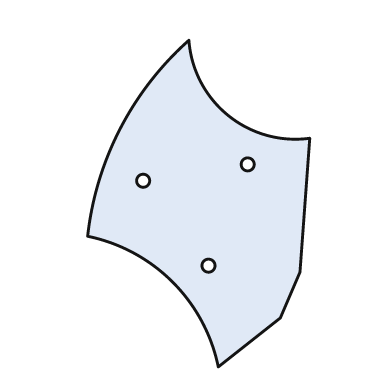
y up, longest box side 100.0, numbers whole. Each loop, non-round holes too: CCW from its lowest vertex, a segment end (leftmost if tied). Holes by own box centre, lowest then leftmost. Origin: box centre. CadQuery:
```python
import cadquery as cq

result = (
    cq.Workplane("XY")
    .moveTo(6.0, -50.0)
    .lineTo(25.0, -35.0)
    .lineTo(31.0, -21.0)
    .lineTo(34.0, 20.0)
    .threePointArc((9.0, 27.0), (-3.0, 50.0))
    .threePointArc((-24.0, 23.0), (-34.0, -10.0))
    .threePointArc((-8.0, -24.0), (6.0, -50.0))
    .close()
    .moveTo(3.0, -19.0)
    .circle(2.0)
    .moveTo(-17.0, 7.0)
    .circle(2.0)
    .moveTo(15.0, 12.0)
    .circle(2.0)
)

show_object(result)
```